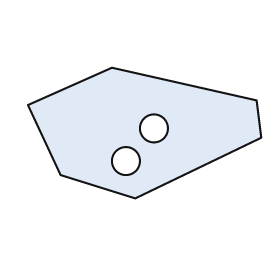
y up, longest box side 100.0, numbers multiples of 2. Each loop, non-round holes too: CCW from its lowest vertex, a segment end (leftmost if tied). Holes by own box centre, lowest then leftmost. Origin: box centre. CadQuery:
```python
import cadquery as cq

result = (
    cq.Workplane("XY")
    .moveTo(-4.0, -28.0)
    .lineTo(50.0, -2.0)
    .lineTo(48.0, 14.0)
    .lineTo(-14.0, 28.0)
    .lineTo(-50.0, 12.0)
    .lineTo(-36.0, -18.0)
    .close()
    .moveTo(-8.0, -12.0)
    .circle(6.0)
    .moveTo(4.0, 2.0)
    .circle(6.0)
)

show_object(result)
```